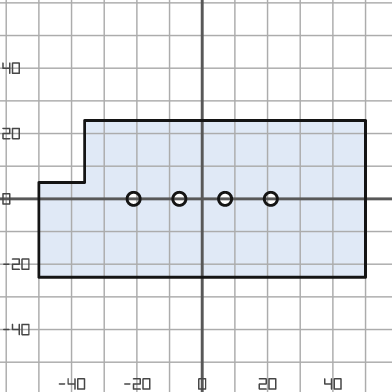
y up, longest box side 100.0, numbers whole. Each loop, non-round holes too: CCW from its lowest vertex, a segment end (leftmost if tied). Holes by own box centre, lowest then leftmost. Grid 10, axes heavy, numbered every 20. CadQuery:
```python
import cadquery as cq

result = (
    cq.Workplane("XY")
    .moveTo(-50.0, -24.0)
    .lineTo(50.0, -24.0)
    .lineTo(50.0, 24.0)
    .lineTo(-36.0, 24.0)
    .lineTo(-36.0, 5.0)
    .lineTo(-50.0, 5.0)
    .close()
    .moveTo(-21.0, 0.0)
    .circle(2.0)
    .moveTo(-7.0, 0.0)
    .circle(2.0)
    .moveTo(7.0, 0.0)
    .circle(2.0)
    .moveTo(21.0, 0.0)
    .circle(2.0)
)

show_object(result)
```